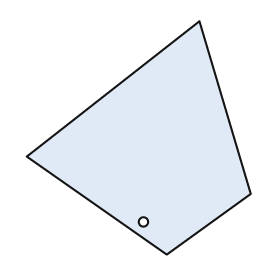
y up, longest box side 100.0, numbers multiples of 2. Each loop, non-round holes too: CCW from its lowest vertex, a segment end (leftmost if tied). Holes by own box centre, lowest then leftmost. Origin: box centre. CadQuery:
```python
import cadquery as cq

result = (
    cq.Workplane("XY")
    .moveTo(12.0, -50.0)
    .lineTo(48.0, -24.0)
    .lineTo(26.0, 50.0)
    .lineTo(-48.0, -8.0)
    .close()
    .moveTo(2.0, -36.0)
    .circle(2.0)
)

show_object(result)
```